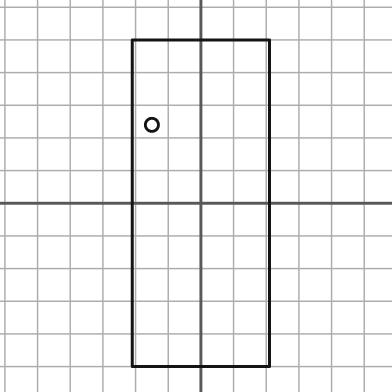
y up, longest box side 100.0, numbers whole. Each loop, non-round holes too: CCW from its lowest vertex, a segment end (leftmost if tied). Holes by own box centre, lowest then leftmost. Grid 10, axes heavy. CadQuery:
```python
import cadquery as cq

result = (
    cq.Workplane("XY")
    .moveTo(-21.0, -50.0)
    .lineTo(21.0, -50.0)
    .lineTo(21.0, 50.0)
    .lineTo(-21.0, 50.0)
    .close()
    .moveTo(-15.0, 24.0)
    .circle(2.0)
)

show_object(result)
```